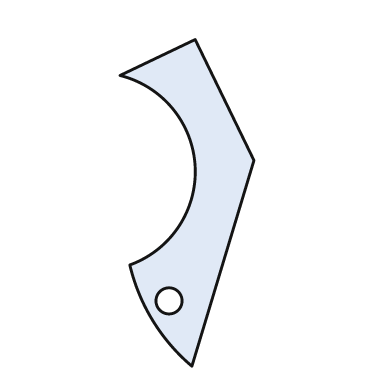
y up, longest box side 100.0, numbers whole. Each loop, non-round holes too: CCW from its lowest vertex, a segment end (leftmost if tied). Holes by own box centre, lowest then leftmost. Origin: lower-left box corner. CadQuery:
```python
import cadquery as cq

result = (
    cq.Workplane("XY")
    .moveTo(22.0, 0.0)
    .lineTo(41.0, 63.0)
    .lineTo(23.0, 100.0)
    .lineTo(0.0, 89.0)
    .threePointArc((23.0, 61.0), (3.0, 31.0))
    .threePointArc((10.0, 14.0), (22.0, 0.0))
    .close()
    .moveTo(15.0, 20.0)
    .circle(4.0)
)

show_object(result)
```